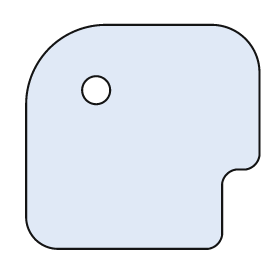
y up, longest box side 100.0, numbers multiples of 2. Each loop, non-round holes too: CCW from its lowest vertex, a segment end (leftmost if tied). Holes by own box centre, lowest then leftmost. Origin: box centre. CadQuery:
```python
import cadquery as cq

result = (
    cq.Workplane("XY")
    .moveTo(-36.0, -48.0)
    .lineTo(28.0, -48.0)
    .threePointArc((32.0, -46.0), (34.0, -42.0))
    .lineTo(34.0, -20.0)
    .threePointArc((36.0, -16.0), (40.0, -14.0))
    .lineTo(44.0, -14.0)
    .threePointArc((48.0, -12.0), (50.0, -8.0))
    .lineTo(50.0, 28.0)
    .threePointArc((44.0, 42.0), (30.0, 48.0))
    .lineTo(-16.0, 48.0)
    .threePointArc((-40.0, 38.0), (-50.0, 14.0))
    .lineTo(-50.0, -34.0)
    .threePointArc((-46.0, -44.0), (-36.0, -48.0))
    .close()
    .moveTo(-20.0, 20.0)
    .circle(6.0)
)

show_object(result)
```